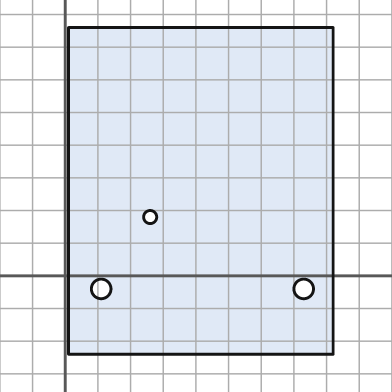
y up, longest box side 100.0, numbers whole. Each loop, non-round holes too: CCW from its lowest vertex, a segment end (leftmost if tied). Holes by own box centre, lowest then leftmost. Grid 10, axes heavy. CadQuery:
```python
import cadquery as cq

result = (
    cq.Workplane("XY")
    .moveTo(1.0, -24.0)
    .lineTo(82.0, -24.0)
    .lineTo(82.0, 76.0)
    .lineTo(1.0, 76.0)
    .close()
    .moveTo(11.0, -4.0)
    .circle(3.0)
    .moveTo(73.0, -4.0)
    .circle(3.0)
    .moveTo(26.0, 18.0)
    .circle(2.0)
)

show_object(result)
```